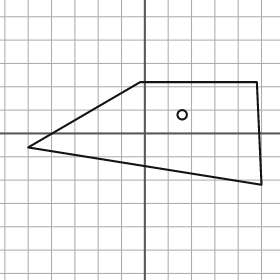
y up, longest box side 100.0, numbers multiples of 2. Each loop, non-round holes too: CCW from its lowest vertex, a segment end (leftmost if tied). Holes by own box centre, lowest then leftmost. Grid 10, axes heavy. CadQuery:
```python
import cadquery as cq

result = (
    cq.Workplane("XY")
    .moveTo(50.0, -22.0)
    .lineTo(48.0, 22.0)
    .lineTo(-2.0, 22.0)
    .lineTo(-50.0, -6.0)
    .close()
    .moveTo(16.0, 8.0)
    .circle(2.0)
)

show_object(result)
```